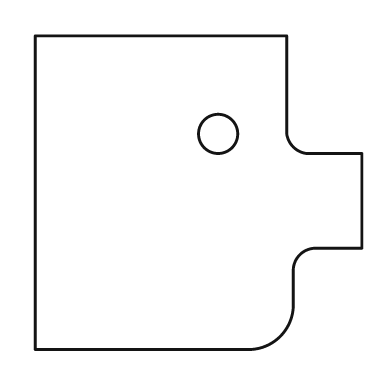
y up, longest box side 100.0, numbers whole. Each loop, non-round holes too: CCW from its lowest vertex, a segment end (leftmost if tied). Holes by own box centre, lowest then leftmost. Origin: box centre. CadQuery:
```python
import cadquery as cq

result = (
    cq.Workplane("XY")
    .moveTo(-50.0, -48.0)
    .lineTo(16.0, -48.0)
    .threePointArc((25.0, -44.0), (29.0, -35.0))
    .lineTo(29.0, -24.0)
    .threePointArc((31.0, -19.0), (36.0, -17.0))
    .lineTo(50.0, -17.0)
    .lineTo(50.0, 12.0)
    .lineTo(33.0, 12.0)
    .threePointArc((29.0, 14.0), (27.0, 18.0))
    .lineTo(27.0, 48.0)
    .lineTo(-50.0, 48.0)
    .close()
    .moveTo(6.0, 18.0)
    .circle(6.0)
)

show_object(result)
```